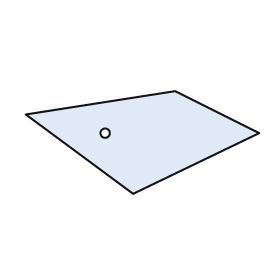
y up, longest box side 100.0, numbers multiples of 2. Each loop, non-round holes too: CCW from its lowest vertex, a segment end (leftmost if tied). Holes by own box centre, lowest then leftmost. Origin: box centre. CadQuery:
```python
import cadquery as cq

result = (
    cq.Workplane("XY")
    .moveTo(-4.0, -22.0)
    .lineTo(50.0, 4.0)
    .lineTo(14.0, 22.0)
    .lineTo(-50.0, 12.0)
    .close()
    .moveTo(-16.0, 4.0)
    .circle(2.0)
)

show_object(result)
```